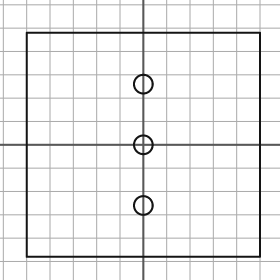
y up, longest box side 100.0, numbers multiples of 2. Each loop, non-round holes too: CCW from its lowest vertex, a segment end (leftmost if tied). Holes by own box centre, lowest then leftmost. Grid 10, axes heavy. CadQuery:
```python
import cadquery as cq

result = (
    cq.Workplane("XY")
    .moveTo(-50.0, -48.0)
    .lineTo(50.0, -48.0)
    .lineTo(50.0, 48.0)
    .lineTo(-50.0, 48.0)
    .close()
    .moveTo(0.0, -26.0)
    .circle(4.0)
    .moveTo(0.0, 0.0)
    .circle(4.0)
    .moveTo(0.0, 26.0)
    .circle(4.0)
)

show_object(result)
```